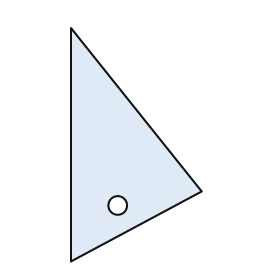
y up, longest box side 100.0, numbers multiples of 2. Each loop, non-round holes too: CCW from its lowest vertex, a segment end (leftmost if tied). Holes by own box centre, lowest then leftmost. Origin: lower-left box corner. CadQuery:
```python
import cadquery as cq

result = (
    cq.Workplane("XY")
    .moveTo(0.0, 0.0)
    .lineTo(56.0, 30.0)
    .lineTo(0.0, 100.0)
    .close()
    .moveTo(20.0, 24.0)
    .circle(4.0)
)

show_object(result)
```